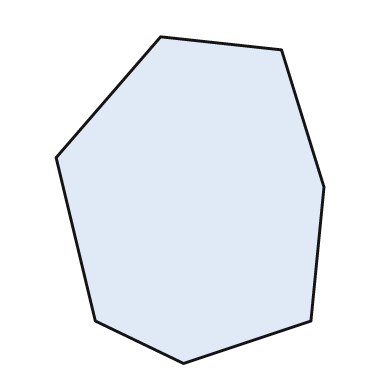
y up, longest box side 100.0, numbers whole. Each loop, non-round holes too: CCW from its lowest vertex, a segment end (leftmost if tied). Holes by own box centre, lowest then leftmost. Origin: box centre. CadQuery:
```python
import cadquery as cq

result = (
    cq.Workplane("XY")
    .moveTo(-2.0, -50.0)
    .lineTo(37.0, -37.0)
    .lineTo(41.0, 4.0)
    .lineTo(28.0, 46.0)
    .lineTo(-9.0, 50.0)
    .lineTo(-41.0, 13.0)
    .lineTo(-29.0, -37.0)
    .close()
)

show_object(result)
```